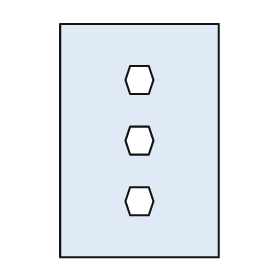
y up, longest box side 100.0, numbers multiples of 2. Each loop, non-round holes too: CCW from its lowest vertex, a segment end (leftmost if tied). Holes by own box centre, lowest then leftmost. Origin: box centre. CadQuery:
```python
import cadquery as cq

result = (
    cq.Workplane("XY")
    .moveTo(-34.0, -50.0)
    .lineTo(34.0, -50.0)
    .lineTo(34.0, 50.0)
    .lineTo(-34.0, 50.0)
    .close()
    .moveTo(-4.0, -32.0)
    .lineTo(4.0, -32.0)
    .lineTo(6.0, -26.0)
    .lineTo(4.0, -20.0)
    .lineTo(-4.0, -20.0)
    .lineTo(-6.0, -26.0)
    .close()
    .moveTo(-4.0, -6.0)
    .lineTo(4.0, -6.0)
    .lineTo(6.0, 0.0)
    .lineTo(4.0, 6.0)
    .lineTo(-4.0, 6.0)
    .lineTo(-6.0, 0.0)
    .close()
    .moveTo(-4.0, 20.0)
    .lineTo(4.0, 20.0)
    .lineTo(6.0, 26.0)
    .lineTo(4.0, 32.0)
    .lineTo(-4.0, 32.0)
    .lineTo(-6.0, 26.0)
    .close()
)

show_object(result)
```